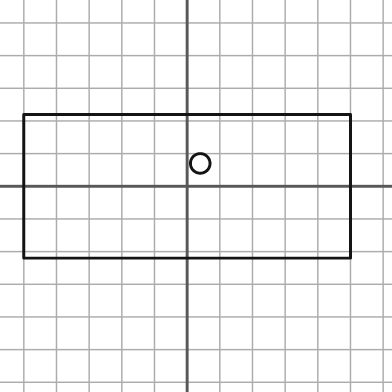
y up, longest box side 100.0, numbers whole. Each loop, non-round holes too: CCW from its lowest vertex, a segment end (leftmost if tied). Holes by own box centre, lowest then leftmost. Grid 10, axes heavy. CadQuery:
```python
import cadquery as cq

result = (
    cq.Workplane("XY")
    .moveTo(-50.0, -22.0)
    .lineTo(50.0, -22.0)
    .lineTo(50.0, 22.0)
    .lineTo(-50.0, 22.0)
    .close()
    .moveTo(4.0, 7.0)
    .circle(3.0)
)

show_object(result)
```